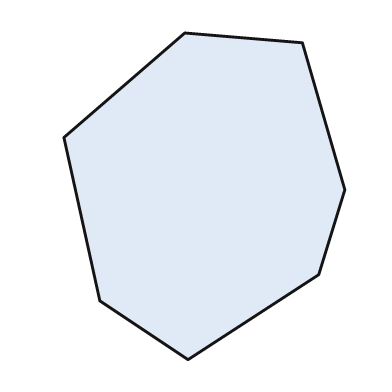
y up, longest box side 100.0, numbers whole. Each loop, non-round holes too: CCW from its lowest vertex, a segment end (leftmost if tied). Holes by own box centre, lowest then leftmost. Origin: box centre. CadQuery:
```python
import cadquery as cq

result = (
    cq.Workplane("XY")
    .moveTo(-5.0, -50.0)
    .lineTo(35.0, -24.0)
    .lineTo(43.0, 2.0)
    .lineTo(30.0, 47.0)
    .lineTo(-6.0, 50.0)
    .lineTo(-43.0, 18.0)
    .lineTo(-32.0, -32.0)
    .close()
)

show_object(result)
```